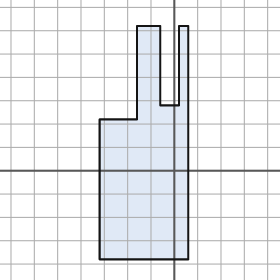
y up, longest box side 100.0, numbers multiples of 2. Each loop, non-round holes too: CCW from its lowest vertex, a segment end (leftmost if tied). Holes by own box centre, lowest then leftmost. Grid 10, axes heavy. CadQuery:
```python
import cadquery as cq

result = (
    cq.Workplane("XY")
    .moveTo(-32.0, -38.0)
    .lineTo(6.0, -38.0)
    .lineTo(6.0, 62.0)
    .lineTo(2.0, 62.0)
    .lineTo(2.0, 28.0)
    .lineTo(-6.0, 28.0)
    .lineTo(-6.0, 62.0)
    .lineTo(-16.0, 62.0)
    .lineTo(-16.0, 22.0)
    .lineTo(-32.0, 22.0)
    .close()
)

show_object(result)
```